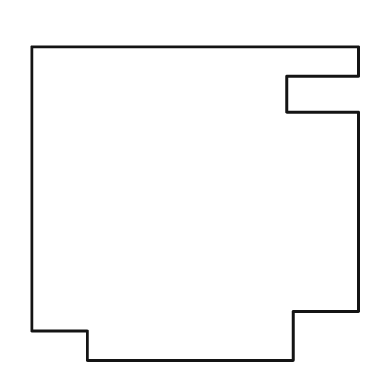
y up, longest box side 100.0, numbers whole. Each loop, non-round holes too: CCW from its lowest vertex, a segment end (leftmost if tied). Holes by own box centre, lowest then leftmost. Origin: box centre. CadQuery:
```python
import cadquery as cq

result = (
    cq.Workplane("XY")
    .moveTo(-33.0, -48.0)
    .lineTo(30.0, -48.0)
    .lineTo(30.0, -33.0)
    .lineTo(50.0, -33.0)
    .lineTo(50.0, 28.0)
    .lineTo(28.0, 28.0)
    .lineTo(28.0, 39.0)
    .lineTo(50.0, 39.0)
    .lineTo(50.0, 48.0)
    .lineTo(-50.0, 48.0)
    .lineTo(-50.0, -39.0)
    .lineTo(-33.0, -39.0)
    .close()
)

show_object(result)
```